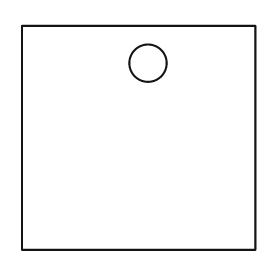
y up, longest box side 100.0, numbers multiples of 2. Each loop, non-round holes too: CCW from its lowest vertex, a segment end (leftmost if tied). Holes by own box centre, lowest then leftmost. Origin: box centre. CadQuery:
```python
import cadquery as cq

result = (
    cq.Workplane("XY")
    .moveTo(-50.0, -48.0)
    .lineTo(50.0, -48.0)
    .lineTo(50.0, 48.0)
    .lineTo(-50.0, 48.0)
    .close()
    .moveTo(4.0, 32.0)
    .circle(8.0)
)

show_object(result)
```